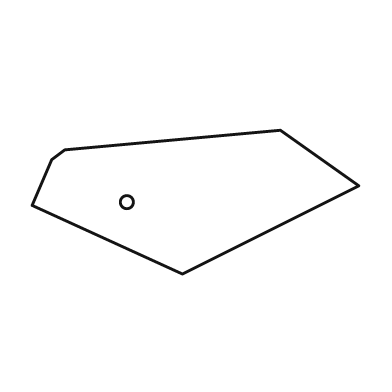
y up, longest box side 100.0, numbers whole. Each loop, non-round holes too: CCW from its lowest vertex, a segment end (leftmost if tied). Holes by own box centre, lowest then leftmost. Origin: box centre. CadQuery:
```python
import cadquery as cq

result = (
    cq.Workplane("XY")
    .moveTo(-4.0, -22.0)
    .lineTo(50.0, 5.0)
    .lineTo(26.0, 22.0)
    .lineTo(-40.0, 16.0)
    .lineTo(-44.0, 13.0)
    .lineTo(-50.0, -1.0)
    .close()
    .moveTo(-21.0, 0.0)
    .circle(2.0)
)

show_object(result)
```